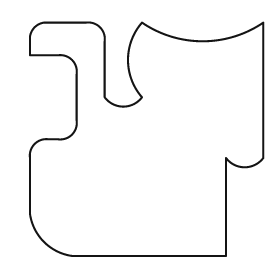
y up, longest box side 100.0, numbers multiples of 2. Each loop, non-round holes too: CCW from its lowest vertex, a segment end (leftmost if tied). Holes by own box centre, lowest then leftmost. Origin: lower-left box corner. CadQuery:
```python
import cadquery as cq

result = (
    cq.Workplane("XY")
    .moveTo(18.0, 0.0)
    .lineTo(84.0, 0.0)
    .lineTo(84.0, 42.0)
    .threePointArc((92.0, 38.0), (100.0, 42.0))
    .lineTo(100.0, 100.0)
    .threePointArc((74.0, 92.0), (48.0, 100.0))
    .threePointArc((42.0, 84.0), (48.0, 68.0))
    .threePointArc((40.0, 64.0), (32.0, 68.0))
    .lineTo(32.0, 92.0)
    .threePointArc((30.0, 98.0), (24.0, 100.0))
    .lineTo(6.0, 100.0)
    .threePointArc((2.0, 98.0), (0.0, 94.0))
    .lineTo(0.0, 86.0)
    .lineTo(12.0, 86.0)
    .threePointArc((18.0, 84.0), (20.0, 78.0))
    .lineTo(20.0, 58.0)
    .threePointArc((18.0, 52.0), (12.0, 50.0))
    .lineTo(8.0, 50.0)
    .threePointArc((2.0, 48.0), (0.0, 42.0))
    .lineTo(0.0, 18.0)
    .threePointArc((6.0, 6.0), (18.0, 0.0))
    .close()
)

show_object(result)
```